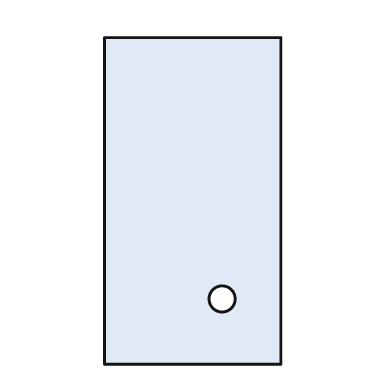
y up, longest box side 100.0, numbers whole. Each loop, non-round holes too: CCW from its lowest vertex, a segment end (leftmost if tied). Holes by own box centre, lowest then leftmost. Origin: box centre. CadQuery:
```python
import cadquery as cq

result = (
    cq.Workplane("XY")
    .moveTo(-27.0, -50.0)
    .lineTo(27.0, -50.0)
    .lineTo(27.0, 50.0)
    .lineTo(-27.0, 50.0)
    .close()
    .moveTo(9.0, -30.0)
    .circle(4.0)
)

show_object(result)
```